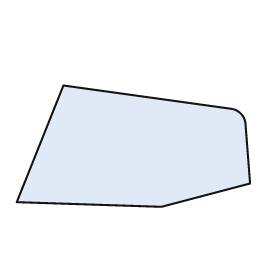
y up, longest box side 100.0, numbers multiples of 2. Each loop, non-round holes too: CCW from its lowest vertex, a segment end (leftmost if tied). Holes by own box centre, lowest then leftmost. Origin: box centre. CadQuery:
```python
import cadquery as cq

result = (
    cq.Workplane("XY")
    .moveTo(12.0, -26.0)
    .lineTo(50.0, -16.0)
    .lineTo(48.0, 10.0)
    .threePointArc((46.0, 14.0), (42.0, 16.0))
    .lineTo(-30.0, 26.0)
    .lineTo(-50.0, -24.0)
    .close()
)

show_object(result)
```